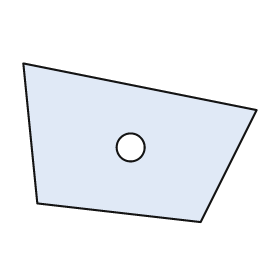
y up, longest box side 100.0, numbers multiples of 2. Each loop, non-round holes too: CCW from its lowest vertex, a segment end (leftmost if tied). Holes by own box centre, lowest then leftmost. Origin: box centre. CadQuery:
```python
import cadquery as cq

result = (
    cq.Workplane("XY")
    .moveTo(26.0, -34.0)
    .lineTo(50.0, 14.0)
    .lineTo(-50.0, 34.0)
    .lineTo(-44.0, -26.0)
    .close()
    .moveTo(-4.0, -2.0)
    .circle(6.0)
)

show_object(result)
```